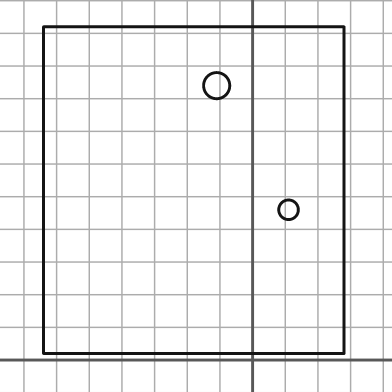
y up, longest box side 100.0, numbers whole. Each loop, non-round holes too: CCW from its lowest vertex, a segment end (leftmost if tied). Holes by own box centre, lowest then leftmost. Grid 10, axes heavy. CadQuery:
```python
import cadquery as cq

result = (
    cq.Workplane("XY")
    .moveTo(-64.0, 2.0)
    .lineTo(28.0, 2.0)
    .lineTo(28.0, 102.0)
    .lineTo(-64.0, 102.0)
    .close()
    .moveTo(11.0, 46.0)
    .circle(3.0)
    .moveTo(-11.0, 84.0)
    .circle(4.0)
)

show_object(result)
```